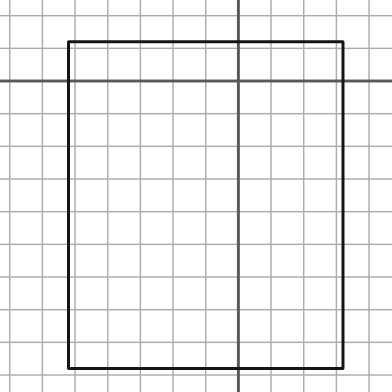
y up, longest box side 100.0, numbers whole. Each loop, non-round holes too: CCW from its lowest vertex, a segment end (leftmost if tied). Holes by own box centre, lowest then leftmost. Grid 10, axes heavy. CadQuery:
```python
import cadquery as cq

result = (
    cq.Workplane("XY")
    .moveTo(-52.0, -88.0)
    .lineTo(32.0, -88.0)
    .lineTo(32.0, 12.0)
    .lineTo(-52.0, 12.0)
    .close()
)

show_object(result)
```